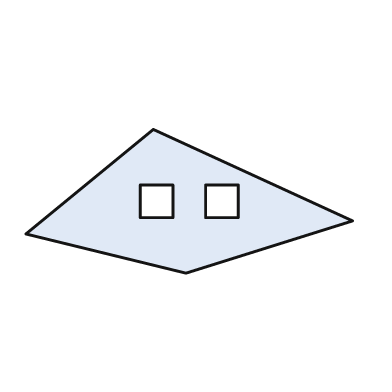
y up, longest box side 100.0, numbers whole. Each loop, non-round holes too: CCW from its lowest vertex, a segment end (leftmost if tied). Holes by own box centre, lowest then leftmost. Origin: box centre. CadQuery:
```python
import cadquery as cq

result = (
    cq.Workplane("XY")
    .moveTo(-1.0, -22.0)
    .lineTo(50.0, -6.0)
    .lineTo(-11.0, 22.0)
    .lineTo(-50.0, -10.0)
    .close()
    .moveTo(-15.0, -5.0)
    .lineTo(-5.0, -5.0)
    .lineTo(-5.0, 5.0)
    .lineTo(-15.0, 5.0)
    .close()
    .moveTo(5.0, -5.0)
    .lineTo(15.0, -5.0)
    .lineTo(15.0, 5.0)
    .lineTo(5.0, 5.0)
    .close()
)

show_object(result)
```